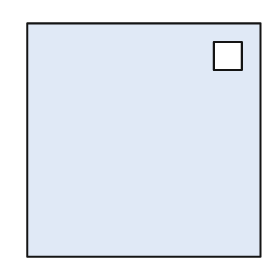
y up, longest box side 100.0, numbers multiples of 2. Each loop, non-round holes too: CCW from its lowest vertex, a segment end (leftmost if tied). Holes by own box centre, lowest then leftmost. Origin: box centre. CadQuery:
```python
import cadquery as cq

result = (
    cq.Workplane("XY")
    .moveTo(-50.0, -50.0)
    .lineTo(50.0, -50.0)
    .lineTo(50.0, 50.0)
    .lineTo(-50.0, 50.0)
    .close()
    .moveTo(30.0, 30.0)
    .lineTo(42.0, 30.0)
    .lineTo(42.0, 42.0)
    .lineTo(30.0, 42.0)
    .close()
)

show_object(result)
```